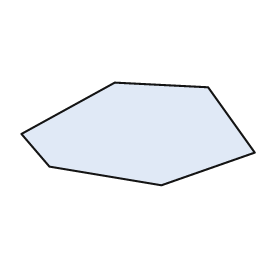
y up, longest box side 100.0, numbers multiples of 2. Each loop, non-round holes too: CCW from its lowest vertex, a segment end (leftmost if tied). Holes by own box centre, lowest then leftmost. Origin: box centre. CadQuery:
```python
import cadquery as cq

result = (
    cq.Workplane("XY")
    .moveTo(10.0, -22.0)
    .lineTo(50.0, -8.0)
    .lineTo(30.0, 20.0)
    .lineTo(-10.0, 22.0)
    .lineTo(-50.0, 0.0)
    .lineTo(-38.0, -14.0)
    .close()
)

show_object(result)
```